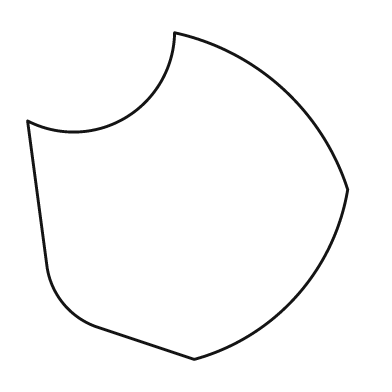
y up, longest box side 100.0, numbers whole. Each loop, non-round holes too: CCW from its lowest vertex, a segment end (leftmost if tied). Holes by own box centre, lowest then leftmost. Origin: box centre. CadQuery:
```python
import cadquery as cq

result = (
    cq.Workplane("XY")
    .moveTo(2.0, -50.0)
    .threePointArc((33.0, -31.0), (49.0, 2.0))
    .threePointArc((29.0, 33.0), (-4.0, 50.0))
    .threePointArc((-19.0, 24.0), (-49.0, 23.0))
    .lineTo(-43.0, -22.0)
    .threePointArc((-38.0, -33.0), (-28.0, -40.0))
    .close()
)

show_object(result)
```